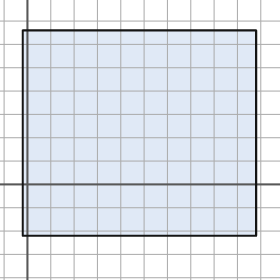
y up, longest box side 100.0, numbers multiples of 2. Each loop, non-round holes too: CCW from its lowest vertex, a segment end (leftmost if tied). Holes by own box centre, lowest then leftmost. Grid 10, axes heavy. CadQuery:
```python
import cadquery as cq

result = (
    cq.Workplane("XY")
    .moveTo(-2.0, -22.0)
    .lineTo(98.0, -22.0)
    .lineTo(98.0, 66.0)
    .lineTo(-2.0, 66.0)
    .close()
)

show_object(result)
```